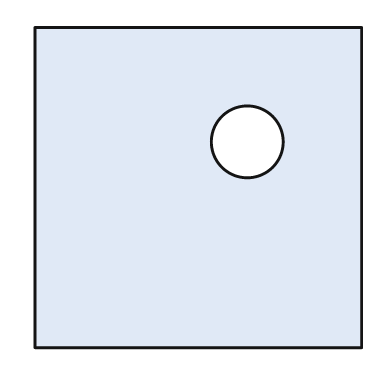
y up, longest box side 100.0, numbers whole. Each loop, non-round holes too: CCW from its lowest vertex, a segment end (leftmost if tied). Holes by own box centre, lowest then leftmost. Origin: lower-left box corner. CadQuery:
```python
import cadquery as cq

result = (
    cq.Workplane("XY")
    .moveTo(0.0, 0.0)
    .lineTo(100.0, 0.0)
    .lineTo(100.0, 98.0)
    .lineTo(0.0, 98.0)
    .close()
    .moveTo(65.0, 63.0)
    .circle(11.0)
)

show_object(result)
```